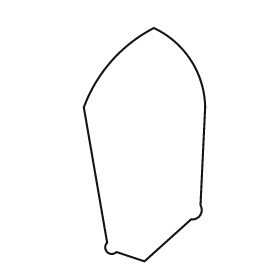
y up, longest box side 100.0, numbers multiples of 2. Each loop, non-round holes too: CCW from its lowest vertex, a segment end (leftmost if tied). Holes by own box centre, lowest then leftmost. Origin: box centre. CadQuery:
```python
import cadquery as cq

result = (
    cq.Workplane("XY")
    .moveTo(0.0, -50.0)
    .lineTo(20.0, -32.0)
    .threePointArc((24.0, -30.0), (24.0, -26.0))
    .lineTo(26.0, 16.0)
    .threePointArc((20.0, 36.0), (4.0, 50.0))
    .threePointArc((-14.0, 36.0), (-26.0, 16.0))
    .lineTo(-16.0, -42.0)
    .threePointArc((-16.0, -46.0), (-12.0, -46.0))
    .close()
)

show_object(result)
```